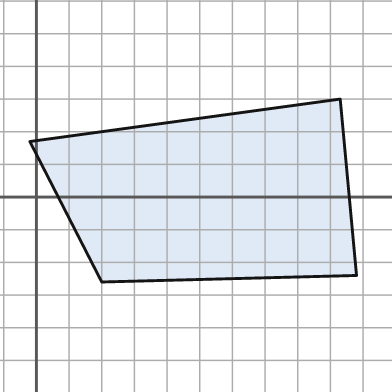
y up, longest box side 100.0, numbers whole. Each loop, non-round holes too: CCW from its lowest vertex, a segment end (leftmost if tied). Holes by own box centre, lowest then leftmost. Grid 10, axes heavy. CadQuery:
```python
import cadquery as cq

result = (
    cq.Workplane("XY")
    .moveTo(20.0, -26.0)
    .lineTo(98.0, -24.0)
    .lineTo(93.0, 30.0)
    .lineTo(-2.0, 17.0)
    .close()
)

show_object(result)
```